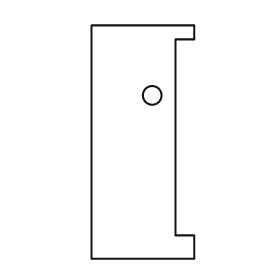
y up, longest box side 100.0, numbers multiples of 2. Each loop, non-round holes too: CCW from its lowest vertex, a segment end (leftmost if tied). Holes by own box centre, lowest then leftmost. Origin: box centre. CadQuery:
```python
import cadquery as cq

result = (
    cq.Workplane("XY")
    .moveTo(-22.0, -50.0)
    .lineTo(22.0, -50.0)
    .lineTo(22.0, -40.0)
    .lineTo(14.0, -40.0)
    .lineTo(14.0, 44.0)
    .lineTo(22.0, 44.0)
    .lineTo(22.0, 50.0)
    .lineTo(-22.0, 50.0)
    .close()
    .moveTo(4.0, 20.0)
    .circle(4.0)
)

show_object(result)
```